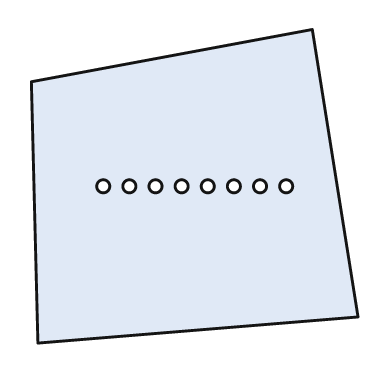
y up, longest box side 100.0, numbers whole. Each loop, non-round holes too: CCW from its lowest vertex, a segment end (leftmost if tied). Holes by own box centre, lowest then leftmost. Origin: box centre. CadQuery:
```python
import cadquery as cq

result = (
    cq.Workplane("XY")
    .moveTo(-48.0, -48.0)
    .lineTo(50.0, -40.0)
    .lineTo(36.0, 48.0)
    .lineTo(-50.0, 32.0)
    .close()
    .moveTo(-28.0, 0.0)
    .circle(2.0)
    .moveTo(-20.0, 0.0)
    .circle(2.0)
    .moveTo(-12.0, 0.0)
    .circle(2.0)
    .moveTo(-4.0, 0.0)
    .circle(2.0)
    .moveTo(4.0, 0.0)
    .circle(2.0)
    .moveTo(12.0, 0.0)
    .circle(2.0)
    .moveTo(20.0, 0.0)
    .circle(2.0)
    .moveTo(28.0, 0.0)
    .circle(2.0)
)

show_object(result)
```